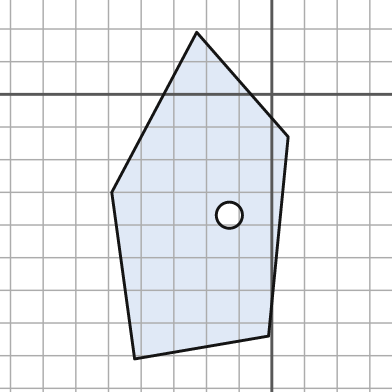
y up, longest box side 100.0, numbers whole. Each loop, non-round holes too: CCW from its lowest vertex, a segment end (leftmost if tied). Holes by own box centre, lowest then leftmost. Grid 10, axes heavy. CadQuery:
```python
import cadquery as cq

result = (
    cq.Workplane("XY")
    .moveTo(-42.0, -81.0)
    .lineTo(-1.0, -74.0)
    .lineTo(5.0, -13.0)
    .lineTo(-23.0, 19.0)
    .lineTo(-49.0, -30.0)
    .close()
    .moveTo(-13.0, -37.0)
    .circle(4.0)
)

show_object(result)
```